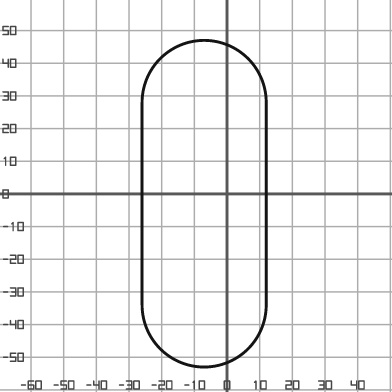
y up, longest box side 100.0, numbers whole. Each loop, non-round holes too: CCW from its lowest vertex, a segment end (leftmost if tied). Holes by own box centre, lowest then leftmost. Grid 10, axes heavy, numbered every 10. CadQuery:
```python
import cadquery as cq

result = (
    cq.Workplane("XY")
    .moveTo(-26.0, -34.0)
    .threePointArc((-7.0, -53.0), (12.0, -34.0))
    .lineTo(12.0, 28.0)
    .threePointArc((-7.0, 47.0), (-26.0, 28.0))
    .close()
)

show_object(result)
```